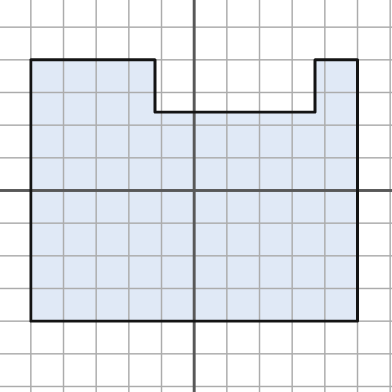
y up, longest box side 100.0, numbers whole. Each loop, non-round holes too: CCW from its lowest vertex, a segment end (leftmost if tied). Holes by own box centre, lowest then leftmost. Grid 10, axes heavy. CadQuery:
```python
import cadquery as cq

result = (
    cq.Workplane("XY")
    .moveTo(-50.0, -40.0)
    .lineTo(50.0, -40.0)
    .lineTo(50.0, 40.0)
    .lineTo(37.0, 40.0)
    .lineTo(37.0, 24.0)
    .lineTo(-12.0, 24.0)
    .lineTo(-12.0, 40.0)
    .lineTo(-50.0, 40.0)
    .close()
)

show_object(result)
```